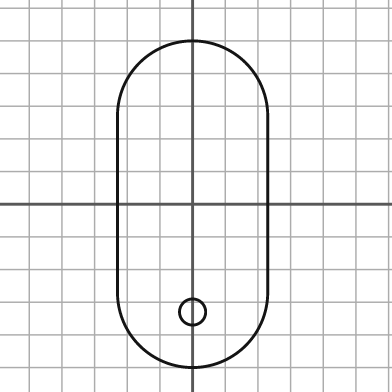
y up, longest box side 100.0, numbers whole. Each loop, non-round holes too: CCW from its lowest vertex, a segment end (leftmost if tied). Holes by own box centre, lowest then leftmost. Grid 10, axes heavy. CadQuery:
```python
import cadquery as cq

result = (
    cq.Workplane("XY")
    .moveTo(-23.0, -27.0)
    .threePointArc((0.0, -50.0), (23.0, -27.0))
    .lineTo(23.0, 27.0)
    .threePointArc((0.0, 50.0), (-23.0, 27.0))
    .close()
    .moveTo(0.0, -33.0)
    .circle(4.0)
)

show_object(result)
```